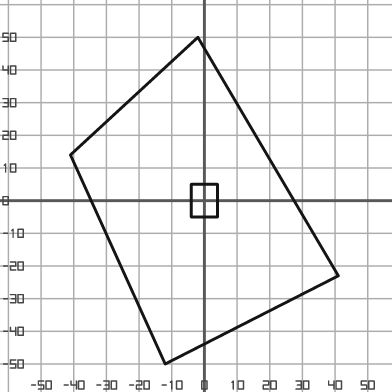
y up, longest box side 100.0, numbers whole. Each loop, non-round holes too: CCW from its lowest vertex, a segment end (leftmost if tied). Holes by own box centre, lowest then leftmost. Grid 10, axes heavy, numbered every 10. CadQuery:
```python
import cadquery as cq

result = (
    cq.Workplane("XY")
    .moveTo(-12.0, -50.0)
    .lineTo(41.0, -23.0)
    .lineTo(-2.0, 50.0)
    .lineTo(-41.0, 14.0)
    .close()
    .moveTo(-4.0, -5.0)
    .lineTo(4.0, -5.0)
    .lineTo(4.0, 5.0)
    .lineTo(-4.0, 5.0)
    .close()
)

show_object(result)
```